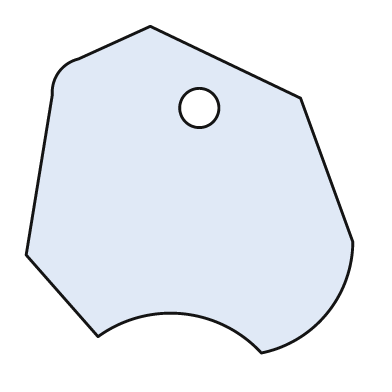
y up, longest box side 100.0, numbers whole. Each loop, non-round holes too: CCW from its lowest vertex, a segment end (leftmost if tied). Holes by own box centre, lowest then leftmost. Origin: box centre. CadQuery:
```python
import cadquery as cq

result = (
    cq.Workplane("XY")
    .moveTo(22.0, -50.0)
    .threePointArc((42.0, -38.0), (50.0, -16.0))
    .lineTo(34.0, 28.0)
    .lineTo(-12.0, 50.0)
    .lineTo(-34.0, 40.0)
    .threePointArc((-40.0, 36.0), (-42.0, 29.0))
    .lineTo(-50.0, -20.0)
    .lineTo(-28.0, -45.0)
    .threePointArc((-2.0, -38.0), (22.0, -50.0))
    .close()
    .moveTo(3.0, 25.0)
    .circle(6.0)
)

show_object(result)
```